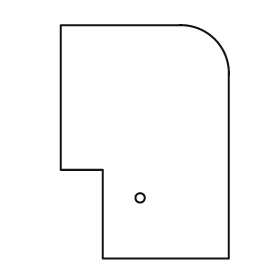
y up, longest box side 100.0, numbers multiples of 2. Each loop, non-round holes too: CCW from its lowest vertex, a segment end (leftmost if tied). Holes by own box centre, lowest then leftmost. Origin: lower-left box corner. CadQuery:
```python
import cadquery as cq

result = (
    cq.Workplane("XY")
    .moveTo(18.0, 0.0)
    .lineTo(72.0, 0.0)
    .lineTo(72.0, 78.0)
    .threePointArc((66.0, 94.0), (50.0, 100.0))
    .lineTo(0.0, 100.0)
    .lineTo(0.0, 38.0)
    .lineTo(18.0, 38.0)
    .close()
    .moveTo(34.0, 26.0)
    .circle(2.0)
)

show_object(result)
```